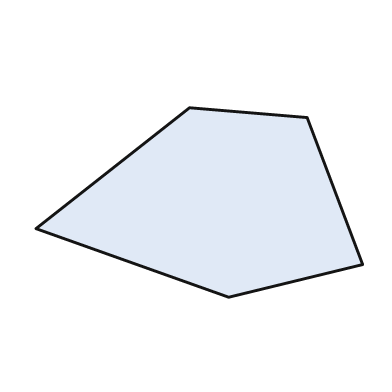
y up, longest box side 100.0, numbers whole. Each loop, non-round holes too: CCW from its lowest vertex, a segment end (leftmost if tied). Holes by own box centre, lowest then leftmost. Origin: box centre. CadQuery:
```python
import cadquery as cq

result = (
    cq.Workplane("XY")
    .moveTo(9.0, -29.0)
    .lineTo(50.0, -19.0)
    .lineTo(33.0, 26.0)
    .lineTo(-3.0, 29.0)
    .lineTo(-50.0, -8.0)
    .close()
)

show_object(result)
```